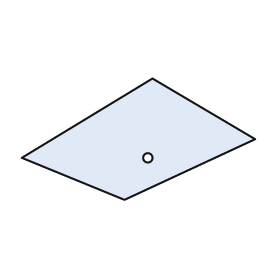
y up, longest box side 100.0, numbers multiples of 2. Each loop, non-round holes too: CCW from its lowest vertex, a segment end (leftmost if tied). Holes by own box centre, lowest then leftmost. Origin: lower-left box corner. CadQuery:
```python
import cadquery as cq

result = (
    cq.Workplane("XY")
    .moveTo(44.0, 0.0)
    .lineTo(100.0, 26.0)
    .lineTo(56.0, 52.0)
    .lineTo(0.0, 18.0)
    .close()
    .moveTo(54.0, 18.0)
    .circle(2.0)
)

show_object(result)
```